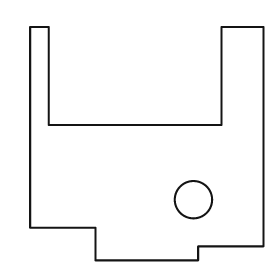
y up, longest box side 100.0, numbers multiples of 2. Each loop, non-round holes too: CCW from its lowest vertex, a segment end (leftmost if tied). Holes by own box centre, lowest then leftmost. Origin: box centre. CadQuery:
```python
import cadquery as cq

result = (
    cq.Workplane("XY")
    .moveTo(-22.0, -50.0)
    .lineTo(22.0, -50.0)
    .lineTo(22.0, -44.0)
    .lineTo(50.0, -44.0)
    .lineTo(50.0, 50.0)
    .lineTo(32.0, 50.0)
    .lineTo(32.0, 8.0)
    .lineTo(-42.0, 8.0)
    .lineTo(-42.0, 50.0)
    .lineTo(-50.0, 50.0)
    .lineTo(-50.0, -36.0)
    .lineTo(-22.0, -36.0)
    .close()
    .moveTo(20.0, -24.0)
    .circle(8.0)
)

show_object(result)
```